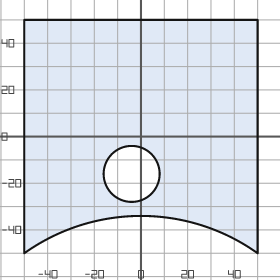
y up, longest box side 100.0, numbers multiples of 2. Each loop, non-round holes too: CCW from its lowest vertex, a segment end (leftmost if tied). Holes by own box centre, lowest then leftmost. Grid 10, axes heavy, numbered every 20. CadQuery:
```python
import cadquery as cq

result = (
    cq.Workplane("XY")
    .moveTo(-50.0, -50.0)
    .threePointArc((0.0, -34.0), (50.0, -50.0))
    .lineTo(50.0, 50.0)
    .lineTo(-50.0, 50.0)
    .close()
    .moveTo(-4.0, -16.0)
    .circle(12.0)
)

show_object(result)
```